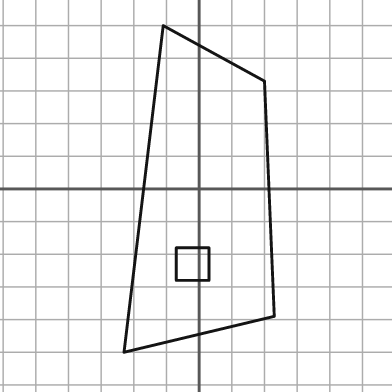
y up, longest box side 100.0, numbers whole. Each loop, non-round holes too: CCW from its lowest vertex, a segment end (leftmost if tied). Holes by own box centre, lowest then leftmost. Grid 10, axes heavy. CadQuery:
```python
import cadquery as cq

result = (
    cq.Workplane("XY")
    .moveTo(-23.0, -50.0)
    .lineTo(23.0, -39.0)
    .lineTo(20.0, 33.0)
    .lineTo(-11.0, 50.0)
    .close()
    .moveTo(-7.0, -28.0)
    .lineTo(3.0, -28.0)
    .lineTo(3.0, -18.0)
    .lineTo(-7.0, -18.0)
    .close()
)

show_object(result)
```